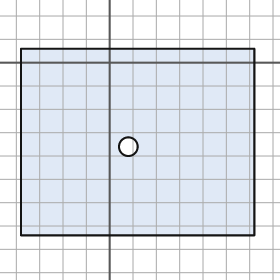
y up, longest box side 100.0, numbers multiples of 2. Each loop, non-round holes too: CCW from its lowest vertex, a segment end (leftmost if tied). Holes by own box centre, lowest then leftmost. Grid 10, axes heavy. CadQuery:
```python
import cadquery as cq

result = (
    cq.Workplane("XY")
    .moveTo(-38.0, -74.0)
    .lineTo(62.0, -74.0)
    .lineTo(62.0, 6.0)
    .lineTo(-38.0, 6.0)
    .close()
    .moveTo(8.0, -36.0)
    .circle(4.0)
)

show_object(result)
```